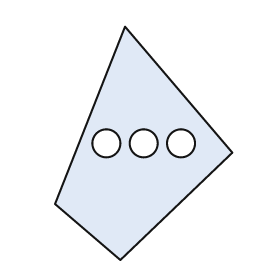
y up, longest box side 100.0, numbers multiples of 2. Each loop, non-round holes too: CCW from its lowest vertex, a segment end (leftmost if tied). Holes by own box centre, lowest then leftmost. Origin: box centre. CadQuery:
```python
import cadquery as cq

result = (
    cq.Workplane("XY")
    .moveTo(-10.0, -50.0)
    .lineTo(38.0, -4.0)
    .lineTo(-8.0, 50.0)
    .lineTo(-38.0, -26.0)
    .close()
    .moveTo(-16.0, 0.0)
    .circle(6.0)
    .moveTo(0.0, 0.0)
    .circle(6.0)
    .moveTo(16.0, 0.0)
    .circle(6.0)
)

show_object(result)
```